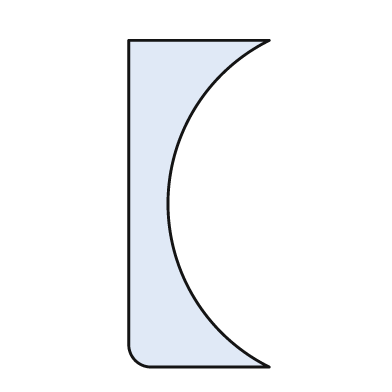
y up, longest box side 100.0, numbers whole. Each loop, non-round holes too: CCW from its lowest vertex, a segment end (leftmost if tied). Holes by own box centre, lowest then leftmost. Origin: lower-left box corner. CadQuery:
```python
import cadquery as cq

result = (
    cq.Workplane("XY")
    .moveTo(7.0, 0.0)
    .lineTo(43.0, 0.0)
    .threePointArc((12.0, 50.0), (43.0, 100.0))
    .lineTo(0.0, 100.0)
    .lineTo(0.0, 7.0)
    .threePointArc((2.0, 2.0), (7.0, 0.0))
    .close()
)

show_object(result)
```